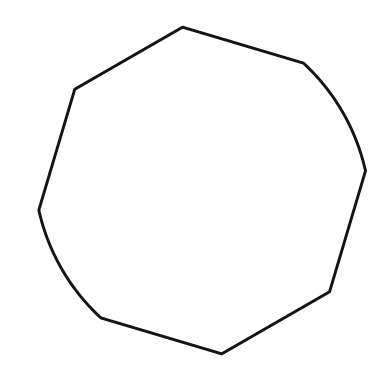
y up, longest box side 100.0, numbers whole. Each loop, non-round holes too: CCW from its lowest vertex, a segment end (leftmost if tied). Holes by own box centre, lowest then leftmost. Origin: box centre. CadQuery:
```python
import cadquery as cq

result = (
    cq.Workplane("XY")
    .moveTo(6.0, -50.0)
    .lineTo(39.0, -31.0)
    .lineTo(50.0, 6.0)
    .threePointArc((43.0, 24.0), (31.0, 39.0))
    .lineTo(-6.0, 50.0)
    .lineTo(-39.0, 31.0)
    .lineTo(-50.0, -6.0)
    .threePointArc((-43.0, -24.0), (-31.0, -39.0))
    .close()
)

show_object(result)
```